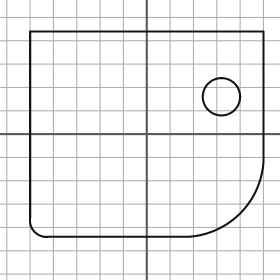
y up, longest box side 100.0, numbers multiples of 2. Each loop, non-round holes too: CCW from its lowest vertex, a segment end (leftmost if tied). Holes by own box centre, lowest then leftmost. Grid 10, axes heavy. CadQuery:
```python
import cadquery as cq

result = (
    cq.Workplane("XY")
    .moveTo(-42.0, -44.0)
    .lineTo(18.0, -44.0)
    .threePointArc((40.0, -34.0), (50.0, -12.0))
    .lineTo(50.0, 44.0)
    .lineTo(-50.0, 44.0)
    .lineTo(-50.0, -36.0)
    .threePointArc((-48.0, -42.0), (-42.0, -44.0))
    .close()
    .moveTo(32.0, 16.0)
    .circle(8.0)
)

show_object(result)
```